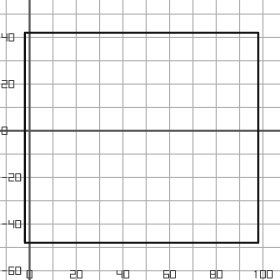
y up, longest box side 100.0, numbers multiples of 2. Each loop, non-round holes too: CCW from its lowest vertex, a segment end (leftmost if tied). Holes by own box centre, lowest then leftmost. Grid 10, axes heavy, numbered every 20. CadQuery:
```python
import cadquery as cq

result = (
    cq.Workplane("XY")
    .moveTo(-2.0, -48.0)
    .lineTo(98.0, -48.0)
    .lineTo(98.0, 42.0)
    .lineTo(-2.0, 42.0)
    .close()
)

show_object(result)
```